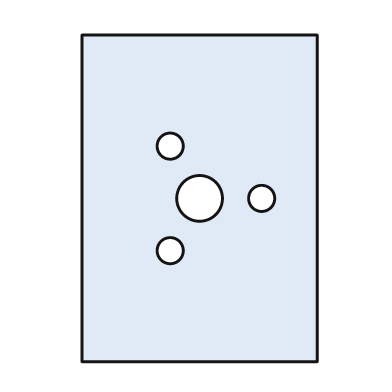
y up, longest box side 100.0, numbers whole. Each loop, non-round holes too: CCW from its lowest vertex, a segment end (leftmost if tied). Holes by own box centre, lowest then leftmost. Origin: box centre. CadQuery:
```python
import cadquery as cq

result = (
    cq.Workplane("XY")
    .moveTo(-36.0, -50.0)
    .lineTo(36.0, -50.0)
    .lineTo(36.0, 50.0)
    .lineTo(-36.0, 50.0)
    .close()
    .moveTo(-9.0, -16.0)
    .circle(4.0)
    .moveTo(0.0, 0.0)
    .circle(7.0)
    .moveTo(19.0, 0.0)
    .circle(4.0)
    .moveTo(-9.0, 16.0)
    .circle(4.0)
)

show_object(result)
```